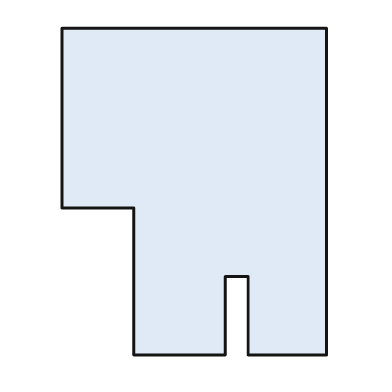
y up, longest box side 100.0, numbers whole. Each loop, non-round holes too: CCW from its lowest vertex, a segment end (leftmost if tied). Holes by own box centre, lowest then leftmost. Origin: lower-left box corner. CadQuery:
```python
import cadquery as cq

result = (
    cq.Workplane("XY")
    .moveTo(22.0, 0.0)
    .lineTo(50.0, 0.0)
    .lineTo(50.0, 24.0)
    .lineTo(57.0, 24.0)
    .lineTo(57.0, 0.0)
    .lineTo(81.0, 0.0)
    .lineTo(81.0, 100.0)
    .lineTo(0.0, 100.0)
    .lineTo(0.0, 45.0)
    .lineTo(22.0, 45.0)
    .close()
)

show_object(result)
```